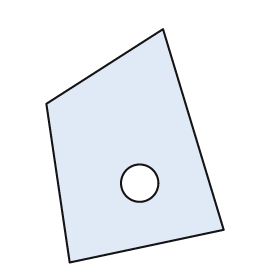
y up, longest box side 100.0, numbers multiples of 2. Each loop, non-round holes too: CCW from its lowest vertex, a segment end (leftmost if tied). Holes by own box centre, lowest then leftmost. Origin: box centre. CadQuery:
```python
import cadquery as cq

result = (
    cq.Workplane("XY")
    .moveTo(-28.0, -50.0)
    .lineTo(38.0, -36.0)
    .lineTo(12.0, 50.0)
    .lineTo(-38.0, 18.0)
    .close()
    .moveTo(2.0, -16.0)
    .circle(8.0)
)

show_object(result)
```